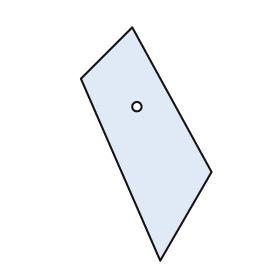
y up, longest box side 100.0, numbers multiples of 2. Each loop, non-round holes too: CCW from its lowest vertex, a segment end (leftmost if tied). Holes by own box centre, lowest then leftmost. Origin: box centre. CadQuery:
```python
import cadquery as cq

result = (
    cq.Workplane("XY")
    .moveTo(6.0, -50.0)
    .lineTo(28.0, -12.0)
    .lineTo(-6.0, 50.0)
    .lineTo(-28.0, 28.0)
    .close()
    .moveTo(-4.0, 16.0)
    .circle(2.0)
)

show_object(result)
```